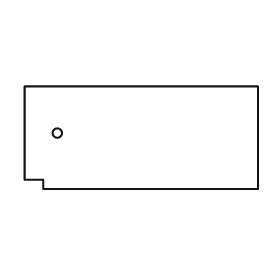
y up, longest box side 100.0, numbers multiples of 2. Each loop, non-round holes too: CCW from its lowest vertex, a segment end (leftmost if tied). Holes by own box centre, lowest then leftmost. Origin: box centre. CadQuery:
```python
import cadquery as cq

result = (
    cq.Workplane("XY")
    .moveTo(-42.0, -22.0)
    .lineTo(50.0, -22.0)
    .lineTo(50.0, 22.0)
    .lineTo(-50.0, 22.0)
    .lineTo(-50.0, -18.0)
    .lineTo(-42.0, -18.0)
    .close()
    .moveTo(-36.0, 2.0)
    .circle(2.0)
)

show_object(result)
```